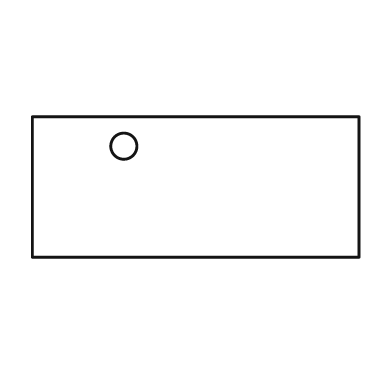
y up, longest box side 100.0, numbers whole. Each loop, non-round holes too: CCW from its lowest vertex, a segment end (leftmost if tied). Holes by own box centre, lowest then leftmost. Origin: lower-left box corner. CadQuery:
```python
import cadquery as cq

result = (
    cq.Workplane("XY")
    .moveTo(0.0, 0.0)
    .lineTo(100.0, 0.0)
    .lineTo(100.0, 43.0)
    .lineTo(0.0, 43.0)
    .close()
    .moveTo(28.0, 34.0)
    .circle(4.0)
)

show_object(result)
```